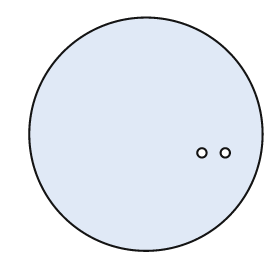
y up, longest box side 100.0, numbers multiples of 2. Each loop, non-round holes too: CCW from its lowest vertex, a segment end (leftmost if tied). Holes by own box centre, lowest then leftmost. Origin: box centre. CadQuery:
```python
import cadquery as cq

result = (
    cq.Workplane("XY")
    .moveTo(0.0, 0.0)
    .circle(50.0)
    .moveTo(24.0, -8.0)
    .circle(2.0)
    .moveTo(34.0, -8.0)
    .circle(2.0)
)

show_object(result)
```